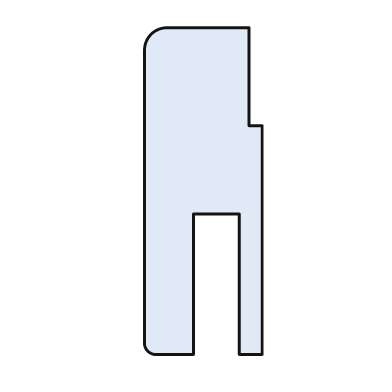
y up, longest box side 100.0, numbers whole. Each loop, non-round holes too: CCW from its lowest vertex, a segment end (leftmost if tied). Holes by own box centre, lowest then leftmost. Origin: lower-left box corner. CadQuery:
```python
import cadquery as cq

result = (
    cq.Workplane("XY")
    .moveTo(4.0, 0.0)
    .lineTo(15.0, 0.0)
    .lineTo(15.0, 43.0)
    .lineTo(29.0, 43.0)
    .lineTo(29.0, 0.0)
    .lineTo(36.0, 0.0)
    .lineTo(36.0, 70.0)
    .lineTo(32.0, 70.0)
    .lineTo(32.0, 100.0)
    .lineTo(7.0, 100.0)
    .threePointArc((2.0, 98.0), (0.0, 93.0))
    .lineTo(0.0, 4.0)
    .threePointArc((1.0, 1.0), (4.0, 0.0))
    .close()
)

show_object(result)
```